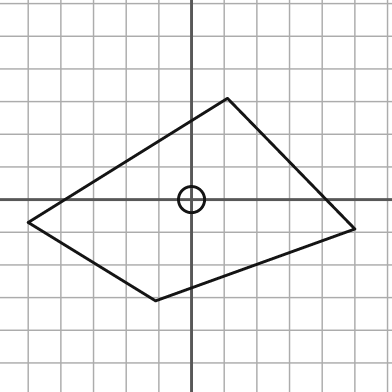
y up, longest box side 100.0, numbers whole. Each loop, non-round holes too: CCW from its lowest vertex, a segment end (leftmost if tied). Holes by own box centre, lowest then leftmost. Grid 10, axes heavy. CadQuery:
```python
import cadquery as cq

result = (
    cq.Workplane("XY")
    .moveTo(-11.0, -31.0)
    .lineTo(50.0, -9.0)
    .lineTo(11.0, 31.0)
    .lineTo(-50.0, -7.0)
    .close()
    .moveTo(0.0, 0.0)
    .circle(4.0)
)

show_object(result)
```